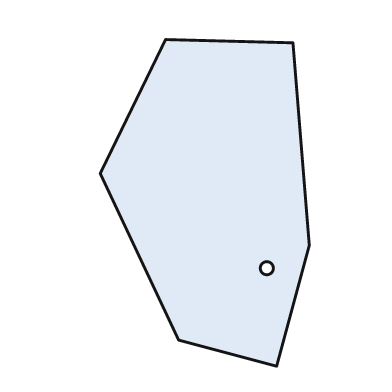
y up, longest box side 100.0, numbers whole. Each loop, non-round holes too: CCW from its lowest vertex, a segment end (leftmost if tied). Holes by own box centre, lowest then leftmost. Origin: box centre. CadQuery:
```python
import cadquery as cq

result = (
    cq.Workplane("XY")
    .moveTo(22.0, -50.0)
    .lineTo(32.0, -13.0)
    .lineTo(27.0, 49.0)
    .lineTo(-12.0, 50.0)
    .lineTo(-32.0, 9.0)
    .lineTo(-8.0, -42.0)
    .close()
    .moveTo(19.0, -20.0)
    .circle(2.0)
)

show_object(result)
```